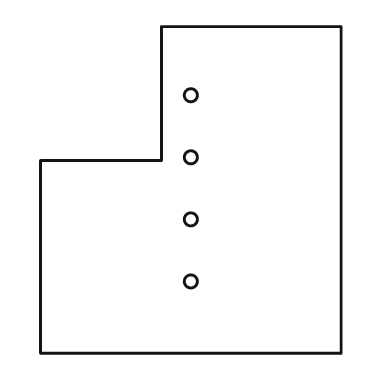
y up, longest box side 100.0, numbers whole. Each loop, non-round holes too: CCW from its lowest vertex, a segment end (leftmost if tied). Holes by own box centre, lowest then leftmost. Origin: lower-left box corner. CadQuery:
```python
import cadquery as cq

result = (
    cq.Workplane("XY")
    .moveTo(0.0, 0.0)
    .lineTo(92.0, 0.0)
    .lineTo(92.0, 100.0)
    .lineTo(37.0, 100.0)
    .lineTo(37.0, 59.0)
    .lineTo(0.0, 59.0)
    .close()
    .moveTo(46.0, 22.0)
    .circle(2.0)
    .moveTo(46.0, 41.0)
    .circle(2.0)
    .moveTo(46.0, 60.0)
    .circle(2.0)
    .moveTo(46.0, 79.0)
    .circle(2.0)
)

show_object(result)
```